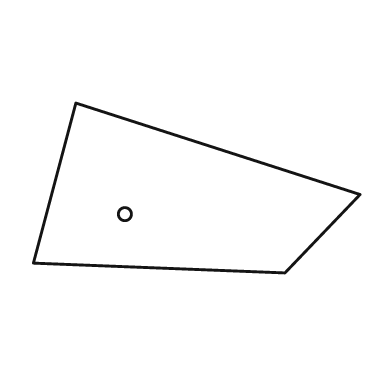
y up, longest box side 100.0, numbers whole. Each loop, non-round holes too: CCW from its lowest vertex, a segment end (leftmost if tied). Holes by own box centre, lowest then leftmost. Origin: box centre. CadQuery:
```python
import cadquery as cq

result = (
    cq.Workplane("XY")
    .moveTo(27.0, -26.0)
    .lineTo(50.0, -2.0)
    .lineTo(-37.0, 26.0)
    .lineTo(-50.0, -23.0)
    .close()
    .moveTo(-22.0, -8.0)
    .circle(2.0)
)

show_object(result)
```